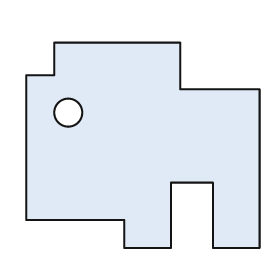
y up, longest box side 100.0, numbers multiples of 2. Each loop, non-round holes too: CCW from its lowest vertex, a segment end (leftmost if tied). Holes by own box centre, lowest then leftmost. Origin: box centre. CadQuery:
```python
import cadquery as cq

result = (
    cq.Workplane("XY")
    .moveTo(-8.0, -44.0)
    .lineTo(12.0, -44.0)
    .lineTo(12.0, -16.0)
    .lineTo(30.0, -16.0)
    .lineTo(30.0, -44.0)
    .lineTo(50.0, -44.0)
    .lineTo(50.0, 24.0)
    .lineTo(16.0, 24.0)
    .lineTo(16.0, 44.0)
    .lineTo(-38.0, 44.0)
    .lineTo(-38.0, 30.0)
    .lineTo(-50.0, 30.0)
    .lineTo(-50.0, -32.0)
    .lineTo(-8.0, -32.0)
    .close()
    .moveTo(-32.0, 14.0)
    .circle(6.0)
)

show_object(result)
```